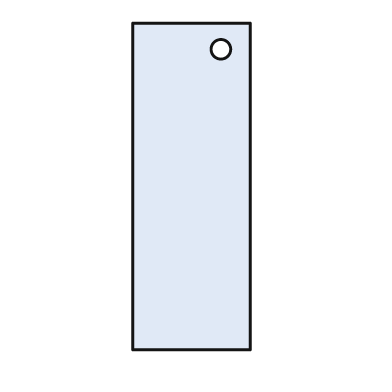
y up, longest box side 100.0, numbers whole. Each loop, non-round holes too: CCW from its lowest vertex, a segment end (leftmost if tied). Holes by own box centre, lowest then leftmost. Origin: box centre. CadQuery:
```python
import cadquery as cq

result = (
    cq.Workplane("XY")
    .moveTo(-18.0, -50.0)
    .lineTo(18.0, -50.0)
    .lineTo(18.0, 50.0)
    .lineTo(-18.0, 50.0)
    .close()
    .moveTo(9.0, 42.0)
    .circle(3.0)
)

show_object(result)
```